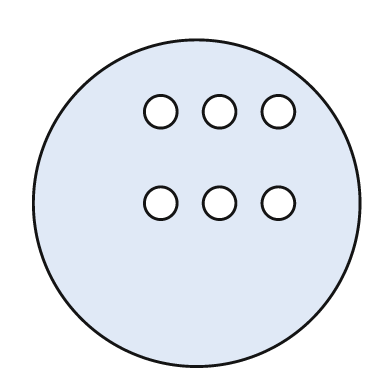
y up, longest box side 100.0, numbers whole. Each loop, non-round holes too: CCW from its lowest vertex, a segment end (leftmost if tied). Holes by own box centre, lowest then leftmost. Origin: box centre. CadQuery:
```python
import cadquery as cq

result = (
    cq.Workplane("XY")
    .moveTo(0.0, 0.0)
    .circle(50.0)
    .moveTo(-11.0, 0.0)
    .circle(5.0)
    .moveTo(7.0, 0.0)
    .circle(5.0)
    .moveTo(25.0, 0.0)
    .circle(5.0)
    .moveTo(-11.0, 28.0)
    .circle(5.0)
    .moveTo(7.0, 28.0)
    .circle(5.0)
    .moveTo(25.0, 28.0)
    .circle(5.0)
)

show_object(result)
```